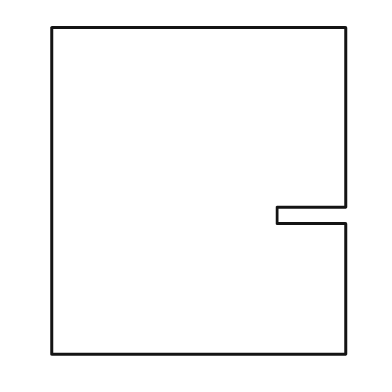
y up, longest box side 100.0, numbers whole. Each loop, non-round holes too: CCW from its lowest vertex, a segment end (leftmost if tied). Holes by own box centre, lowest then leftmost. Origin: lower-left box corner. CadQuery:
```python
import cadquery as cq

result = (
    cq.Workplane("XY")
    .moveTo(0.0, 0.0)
    .lineTo(90.0, 0.0)
    .lineTo(90.0, 40.0)
    .lineTo(69.0, 40.0)
    .lineTo(69.0, 45.0)
    .lineTo(90.0, 45.0)
    .lineTo(90.0, 100.0)
    .lineTo(0.0, 100.0)
    .close()
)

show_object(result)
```